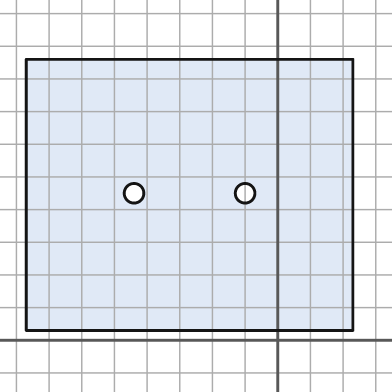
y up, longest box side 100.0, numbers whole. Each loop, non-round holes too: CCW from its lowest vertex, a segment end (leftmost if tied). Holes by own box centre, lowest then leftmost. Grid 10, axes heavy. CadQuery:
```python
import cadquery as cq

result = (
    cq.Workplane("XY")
    .moveTo(-77.0, 3.0)
    .lineTo(23.0, 3.0)
    .lineTo(23.0, 86.0)
    .lineTo(-77.0, 86.0)
    .close()
    .moveTo(-44.0, 45.0)
    .circle(3.0)
    .moveTo(-10.0, 45.0)
    .circle(3.0)
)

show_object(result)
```